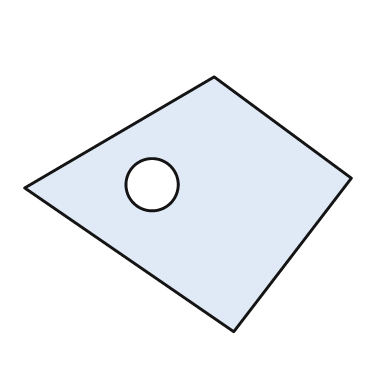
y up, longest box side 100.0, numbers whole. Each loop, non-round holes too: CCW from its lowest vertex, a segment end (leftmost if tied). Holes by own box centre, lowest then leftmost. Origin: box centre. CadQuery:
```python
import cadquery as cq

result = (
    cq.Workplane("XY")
    .moveTo(14.0, -39.0)
    .lineTo(50.0, 8.0)
    .lineTo(8.0, 39.0)
    .lineTo(-50.0, 5.0)
    .close()
    .moveTo(-11.0, 6.0)
    .circle(8.0)
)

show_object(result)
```